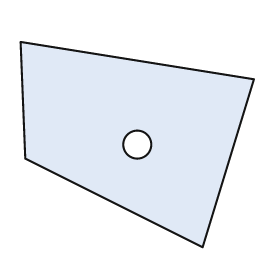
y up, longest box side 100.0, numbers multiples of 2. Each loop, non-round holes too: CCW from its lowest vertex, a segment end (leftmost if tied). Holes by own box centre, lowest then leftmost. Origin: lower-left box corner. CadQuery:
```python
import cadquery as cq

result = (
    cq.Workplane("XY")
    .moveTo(78.0, 0.0)
    .lineTo(100.0, 72.0)
    .lineTo(0.0, 88.0)
    .lineTo(2.0, 38.0)
    .close()
    .moveTo(50.0, 44.0)
    .circle(6.0)
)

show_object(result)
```